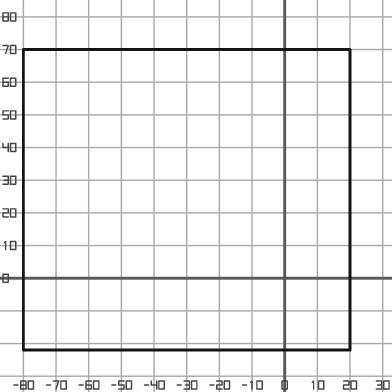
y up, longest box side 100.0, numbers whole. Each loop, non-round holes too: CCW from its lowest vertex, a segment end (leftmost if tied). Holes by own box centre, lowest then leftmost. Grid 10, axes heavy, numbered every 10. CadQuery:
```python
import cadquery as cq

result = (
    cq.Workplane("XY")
    .moveTo(-80.0, -22.0)
    .lineTo(20.0, -22.0)
    .lineTo(20.0, 70.0)
    .lineTo(-80.0, 70.0)
    .close()
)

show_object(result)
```